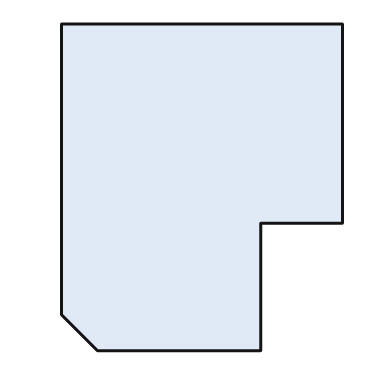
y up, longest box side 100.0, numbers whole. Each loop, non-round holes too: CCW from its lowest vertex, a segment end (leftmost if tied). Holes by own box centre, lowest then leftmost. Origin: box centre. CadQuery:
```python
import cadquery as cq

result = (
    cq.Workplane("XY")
    .moveTo(-32.0, -50.0)
    .lineTo(18.0, -50.0)
    .lineTo(18.0, -11.0)
    .lineTo(43.0, -11.0)
    .lineTo(43.0, 50.0)
    .lineTo(-43.0, 50.0)
    .lineTo(-43.0, -39.0)
    .close()
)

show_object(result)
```